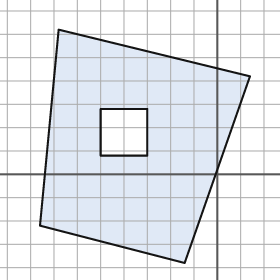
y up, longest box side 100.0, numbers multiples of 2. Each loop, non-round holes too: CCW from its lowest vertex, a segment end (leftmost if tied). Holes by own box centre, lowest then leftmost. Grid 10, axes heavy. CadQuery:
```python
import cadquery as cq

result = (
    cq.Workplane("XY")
    .moveTo(-14.0, -38.0)
    .lineTo(14.0, 42.0)
    .lineTo(-68.0, 62.0)
    .lineTo(-76.0, -22.0)
    .close()
    .moveTo(-50.0, 8.0)
    .lineTo(-30.0, 8.0)
    .lineTo(-30.0, 28.0)
    .lineTo(-50.0, 28.0)
    .close()
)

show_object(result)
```